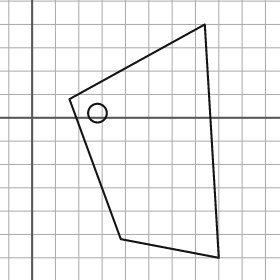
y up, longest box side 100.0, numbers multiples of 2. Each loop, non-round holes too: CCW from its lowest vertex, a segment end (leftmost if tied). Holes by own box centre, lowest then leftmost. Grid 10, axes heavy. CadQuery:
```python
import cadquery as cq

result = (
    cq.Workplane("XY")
    .moveTo(80.0, -60.0)
    .lineTo(74.0, 40.0)
    .lineTo(16.0, 8.0)
    .lineTo(38.0, -52.0)
    .close()
    .moveTo(28.0, 2.0)
    .circle(4.0)
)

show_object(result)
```